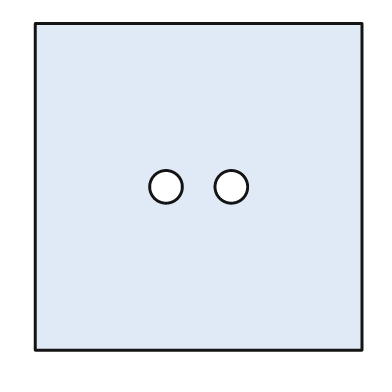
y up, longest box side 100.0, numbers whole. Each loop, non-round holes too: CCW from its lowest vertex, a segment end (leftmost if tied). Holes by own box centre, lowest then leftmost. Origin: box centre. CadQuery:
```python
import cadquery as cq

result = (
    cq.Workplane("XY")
    .moveTo(-50.0, -50.0)
    .lineTo(50.0, -50.0)
    .lineTo(50.0, 50.0)
    .lineTo(-50.0, 50.0)
    .close()
    .moveTo(-10.0, 0.0)
    .circle(5.0)
    .moveTo(10.0, 0.0)
    .circle(5.0)
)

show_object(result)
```